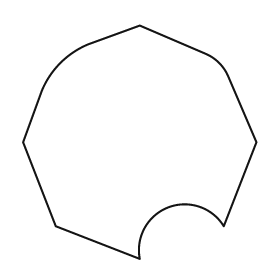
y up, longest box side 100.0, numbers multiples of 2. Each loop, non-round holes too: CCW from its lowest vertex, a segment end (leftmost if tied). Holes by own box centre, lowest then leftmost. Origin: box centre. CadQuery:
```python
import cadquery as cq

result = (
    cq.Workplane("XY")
    .moveTo(0.0, -50.0)
    .threePointArc((12.0, -28.0), (36.0, -36.0))
    .lineTo(50.0, 0.0)
    .lineTo(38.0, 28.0)
    .threePointArc((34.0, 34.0), (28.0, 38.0))
    .lineTo(0.0, 50.0)
    .lineTo(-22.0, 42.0)
    .threePointArc((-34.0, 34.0), (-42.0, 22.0))
    .lineTo(-50.0, 0.0)
    .lineTo(-36.0, -36.0)
    .close()
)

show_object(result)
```